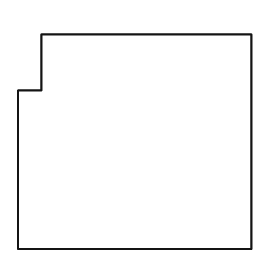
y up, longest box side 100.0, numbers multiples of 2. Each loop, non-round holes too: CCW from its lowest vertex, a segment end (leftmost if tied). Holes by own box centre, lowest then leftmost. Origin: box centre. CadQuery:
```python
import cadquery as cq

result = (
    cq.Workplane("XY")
    .moveTo(-50.0, -46.0)
    .lineTo(50.0, -46.0)
    .lineTo(50.0, 46.0)
    .lineTo(-40.0, 46.0)
    .lineTo(-40.0, 22.0)
    .lineTo(-50.0, 22.0)
    .close()
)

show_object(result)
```